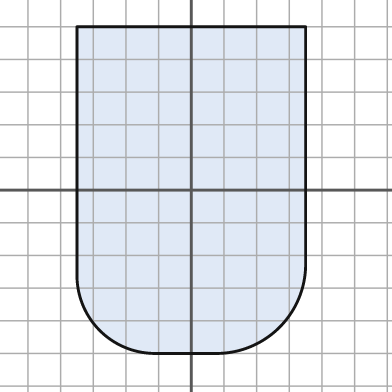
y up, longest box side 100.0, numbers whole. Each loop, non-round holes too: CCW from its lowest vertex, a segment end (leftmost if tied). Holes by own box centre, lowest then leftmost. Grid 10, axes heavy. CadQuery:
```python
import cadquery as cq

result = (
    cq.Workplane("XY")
    .moveTo(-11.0, -50.0)
    .lineTo(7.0, -50.0)
    .threePointArc((27.0, -42.0), (35.0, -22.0))
    .lineTo(35.0, 50.0)
    .lineTo(-35.0, 50.0)
    .lineTo(-35.0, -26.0)
    .threePointArc((-28.0, -43.0), (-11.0, -50.0))
    .close()
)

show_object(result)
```